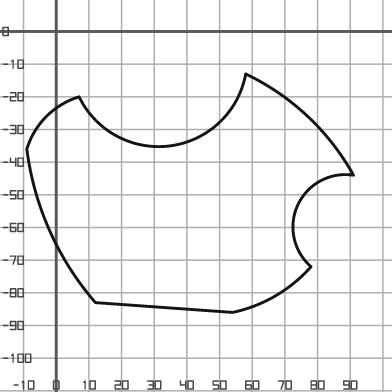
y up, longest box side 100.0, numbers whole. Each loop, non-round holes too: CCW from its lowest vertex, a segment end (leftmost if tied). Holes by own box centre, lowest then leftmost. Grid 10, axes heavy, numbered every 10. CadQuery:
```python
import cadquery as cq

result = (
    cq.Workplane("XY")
    .moveTo(54.0, -86.0)
    .threePointArc((67.0, -81.0), (78.0, -72.0))
    .threePointArc((74.0, -53.0), (91.0, -44.0))
    .threePointArc((77.0, -26.0), (58.0, -13.0))
    .threePointArc((35.0, -35.0), (7.0, -20.0))
    .threePointArc((-3.0, -26.0), (-9.0, -36.0))
    .threePointArc((-2.0, -61.0), (12.0, -83.0))
    .close()
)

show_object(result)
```